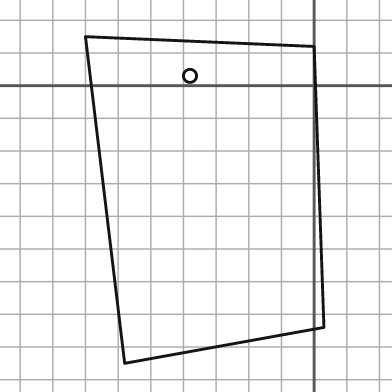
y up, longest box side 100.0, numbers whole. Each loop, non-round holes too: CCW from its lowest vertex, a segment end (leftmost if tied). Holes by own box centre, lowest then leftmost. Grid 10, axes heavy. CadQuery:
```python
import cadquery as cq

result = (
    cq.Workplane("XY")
    .moveTo(-58.0, -85.0)
    .lineTo(3.0, -74.0)
    .lineTo(0.0, 12.0)
    .lineTo(-70.0, 15.0)
    .close()
    .moveTo(-38.0, 3.0)
    .circle(2.0)
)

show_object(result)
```